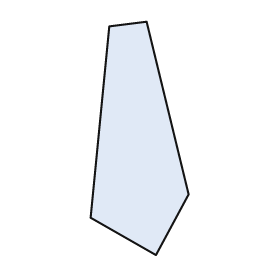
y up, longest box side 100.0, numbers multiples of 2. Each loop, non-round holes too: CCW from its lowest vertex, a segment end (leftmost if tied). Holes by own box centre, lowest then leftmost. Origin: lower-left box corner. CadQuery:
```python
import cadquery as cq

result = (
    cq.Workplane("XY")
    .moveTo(28.0, 0.0)
    .lineTo(42.0, 26.0)
    .lineTo(24.0, 100.0)
    .lineTo(8.0, 98.0)
    .lineTo(0.0, 16.0)
    .close()
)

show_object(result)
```